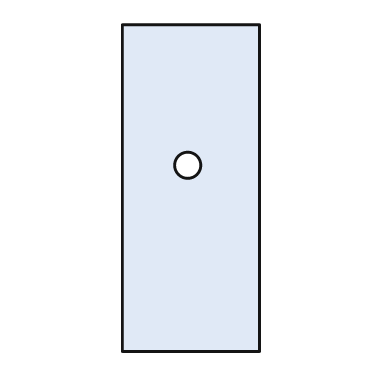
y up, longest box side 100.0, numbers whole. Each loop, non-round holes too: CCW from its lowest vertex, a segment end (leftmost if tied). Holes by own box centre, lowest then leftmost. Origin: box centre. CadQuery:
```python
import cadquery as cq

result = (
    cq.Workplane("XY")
    .moveTo(-21.0, -50.0)
    .lineTo(21.0, -50.0)
    .lineTo(21.0, 50.0)
    .lineTo(-21.0, 50.0)
    .close()
    .moveTo(-1.0, 7.0)
    .circle(4.0)
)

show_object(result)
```